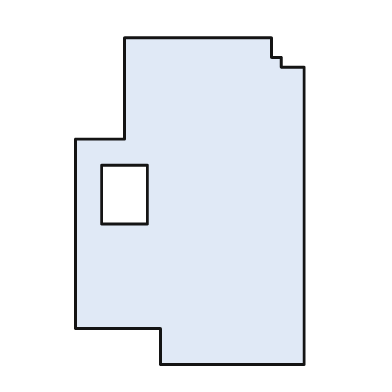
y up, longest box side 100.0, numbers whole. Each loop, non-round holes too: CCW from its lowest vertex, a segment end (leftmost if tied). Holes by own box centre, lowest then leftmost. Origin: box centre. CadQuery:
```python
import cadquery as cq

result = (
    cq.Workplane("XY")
    .moveTo(-9.0, -50.0)
    .lineTo(35.0, -50.0)
    .lineTo(35.0, 41.0)
    .lineTo(28.0, 41.0)
    .lineTo(28.0, 44.0)
    .lineTo(25.0, 44.0)
    .lineTo(25.0, 50.0)
    .lineTo(-20.0, 50.0)
    .lineTo(-20.0, 19.0)
    .lineTo(-35.0, 19.0)
    .lineTo(-35.0, -39.0)
    .lineTo(-9.0, -39.0)
    .close()
    .moveTo(-27.0, -7.0)
    .lineTo(-13.0, -7.0)
    .lineTo(-13.0, 11.0)
    .lineTo(-27.0, 11.0)
    .close()
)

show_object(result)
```